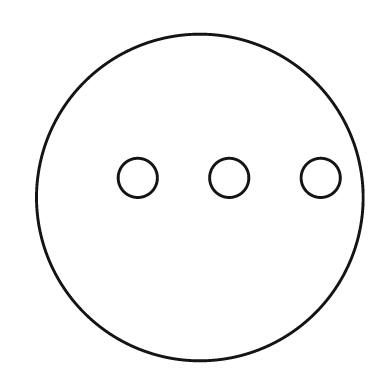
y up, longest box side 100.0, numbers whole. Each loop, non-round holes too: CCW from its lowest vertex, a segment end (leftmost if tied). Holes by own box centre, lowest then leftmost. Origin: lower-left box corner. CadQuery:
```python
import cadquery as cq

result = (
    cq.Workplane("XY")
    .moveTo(50.0, 50.0)
    .circle(50.0)
    .moveTo(31.0, 56.0)
    .circle(6.0)
    .moveTo(59.0, 56.0)
    .circle(6.0)
    .moveTo(87.0, 56.0)
    .circle(6.0)
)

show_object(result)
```